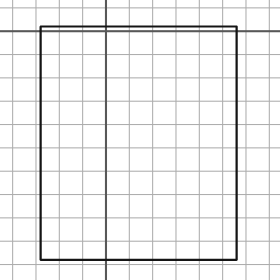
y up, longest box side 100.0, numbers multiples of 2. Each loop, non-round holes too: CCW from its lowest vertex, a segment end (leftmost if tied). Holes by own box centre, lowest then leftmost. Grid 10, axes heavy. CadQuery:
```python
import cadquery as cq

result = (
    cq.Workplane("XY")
    .moveTo(-28.0, -98.0)
    .lineTo(56.0, -98.0)
    .lineTo(56.0, 2.0)
    .lineTo(-28.0, 2.0)
    .close()
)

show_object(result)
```